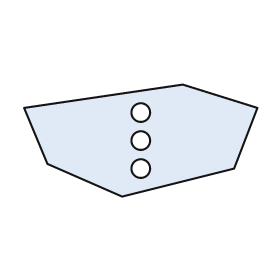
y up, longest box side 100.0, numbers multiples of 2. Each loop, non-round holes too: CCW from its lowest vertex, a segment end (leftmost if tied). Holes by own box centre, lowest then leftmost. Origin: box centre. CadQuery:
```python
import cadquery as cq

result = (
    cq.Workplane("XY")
    .moveTo(-8.0, -24.0)
    .lineTo(40.0, -12.0)
    .lineTo(50.0, 14.0)
    .lineTo(18.0, 24.0)
    .lineTo(-50.0, 14.0)
    .lineTo(-40.0, -10.0)
    .close()
    .moveTo(0.0, -12.0)
    .circle(4.0)
    .moveTo(0.0, 0.0)
    .circle(4.0)
    .moveTo(0.0, 12.0)
    .circle(4.0)
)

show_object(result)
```